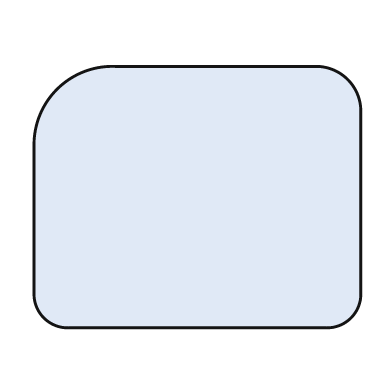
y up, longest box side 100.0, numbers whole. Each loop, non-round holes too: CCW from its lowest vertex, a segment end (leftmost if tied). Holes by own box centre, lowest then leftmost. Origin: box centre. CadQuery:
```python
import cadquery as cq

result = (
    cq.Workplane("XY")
    .moveTo(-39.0, -40.0)
    .lineTo(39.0, -40.0)
    .threePointArc((47.0, -37.0), (50.0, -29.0))
    .lineTo(50.0, 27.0)
    .threePointArc((46.0, 36.0), (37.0, 40.0))
    .lineTo(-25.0, 40.0)
    .threePointArc((-43.0, 33.0), (-50.0, 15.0))
    .lineTo(-50.0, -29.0)
    .threePointArc((-47.0, -37.0), (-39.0, -40.0))
    .close()
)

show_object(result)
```